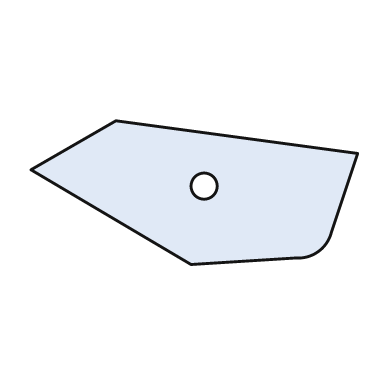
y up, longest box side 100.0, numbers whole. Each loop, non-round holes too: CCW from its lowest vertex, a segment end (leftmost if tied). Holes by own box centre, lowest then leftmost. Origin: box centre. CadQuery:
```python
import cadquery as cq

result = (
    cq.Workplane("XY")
    .moveTo(-1.0, -22.0)
    .lineTo(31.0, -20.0)
    .threePointArc((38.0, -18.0), (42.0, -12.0))
    .lineTo(50.0, 12.0)
    .lineTo(-24.0, 22.0)
    .lineTo(-50.0, 7.0)
    .close()
    .moveTo(3.0, 2.0)
    .circle(4.0)
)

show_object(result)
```